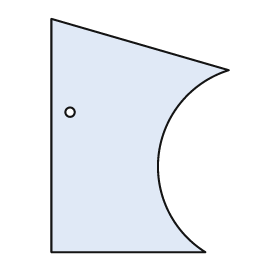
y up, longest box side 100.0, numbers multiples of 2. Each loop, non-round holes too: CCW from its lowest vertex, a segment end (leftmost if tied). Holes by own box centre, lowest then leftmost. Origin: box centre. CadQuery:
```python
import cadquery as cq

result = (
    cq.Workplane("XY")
    .moveTo(-38.0, -50.0)
    .lineTo(28.0, -50.0)
    .threePointArc((8.0, -8.0), (38.0, 28.0))
    .lineTo(-38.0, 50.0)
    .close()
    .moveTo(-30.0, 10.0)
    .circle(2.0)
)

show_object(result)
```